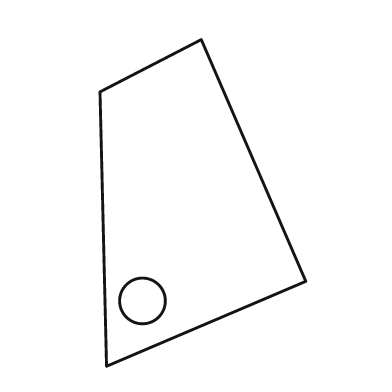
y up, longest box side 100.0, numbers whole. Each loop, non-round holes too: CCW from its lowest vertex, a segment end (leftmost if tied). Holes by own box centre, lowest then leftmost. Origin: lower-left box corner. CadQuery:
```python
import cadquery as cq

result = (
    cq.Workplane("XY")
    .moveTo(2.0, 0.0)
    .lineTo(63.0, 26.0)
    .lineTo(31.0, 100.0)
    .lineTo(0.0, 84.0)
    .close()
    .moveTo(13.0, 20.0)
    .circle(7.0)
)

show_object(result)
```